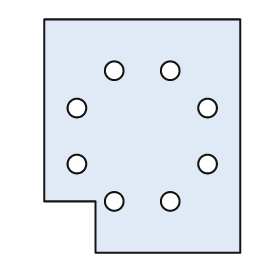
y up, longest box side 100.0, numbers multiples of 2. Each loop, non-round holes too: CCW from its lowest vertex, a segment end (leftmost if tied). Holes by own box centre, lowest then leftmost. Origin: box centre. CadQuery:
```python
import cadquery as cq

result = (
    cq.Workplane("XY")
    .moveTo(-20.0, -50.0)
    .lineTo(42.0, -50.0)
    .lineTo(42.0, 50.0)
    .lineTo(-42.0, 50.0)
    .lineTo(-42.0, -28.0)
    .lineTo(-20.0, -28.0)
    .close()
    .moveTo(-12.0, -28.0)
    .circle(4.0)
    .moveTo(12.0, -28.0)
    .circle(4.0)
    .moveTo(-28.0, -12.0)
    .circle(4.0)
    .moveTo(28.0, -12.0)
    .circle(4.0)
    .moveTo(-28.0, 12.0)
    .circle(4.0)
    .moveTo(28.0, 12.0)
    .circle(4.0)
    .moveTo(-12.0, 28.0)
    .circle(4.0)
    .moveTo(12.0, 28.0)
    .circle(4.0)
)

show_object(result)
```